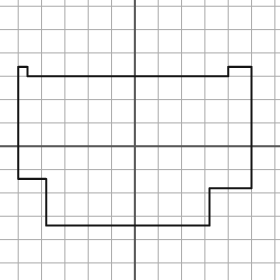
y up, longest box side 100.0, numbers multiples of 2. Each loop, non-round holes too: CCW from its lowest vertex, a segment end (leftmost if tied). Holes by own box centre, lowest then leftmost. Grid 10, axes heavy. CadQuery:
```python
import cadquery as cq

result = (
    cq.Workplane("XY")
    .moveTo(-38.0, -34.0)
    .lineTo(32.0, -34.0)
    .lineTo(32.0, -18.0)
    .lineTo(50.0, -18.0)
    .lineTo(50.0, 34.0)
    .lineTo(40.0, 34.0)
    .lineTo(40.0, 30.0)
    .lineTo(-46.0, 30.0)
    .lineTo(-46.0, 34.0)
    .lineTo(-50.0, 34.0)
    .lineTo(-50.0, -14.0)
    .lineTo(-38.0, -14.0)
    .close()
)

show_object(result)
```